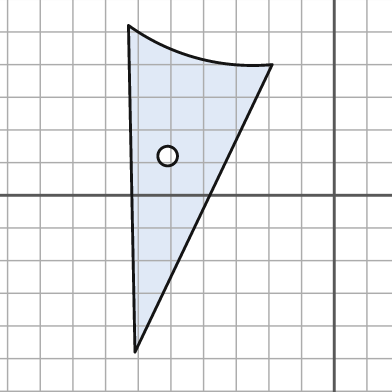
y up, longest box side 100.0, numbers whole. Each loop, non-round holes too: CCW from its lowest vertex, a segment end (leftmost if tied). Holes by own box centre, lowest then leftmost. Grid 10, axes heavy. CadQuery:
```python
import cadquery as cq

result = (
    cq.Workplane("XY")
    .moveTo(-61.0, -48.0)
    .lineTo(-19.0, 40.0)
    .threePointArc((-42.0, 42.0), (-63.0, 52.0))
    .close()
    .moveTo(-51.0, 12.0)
    .circle(3.0)
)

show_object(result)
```